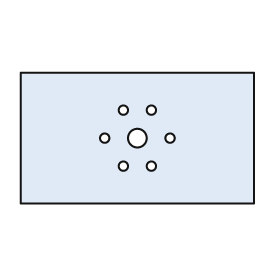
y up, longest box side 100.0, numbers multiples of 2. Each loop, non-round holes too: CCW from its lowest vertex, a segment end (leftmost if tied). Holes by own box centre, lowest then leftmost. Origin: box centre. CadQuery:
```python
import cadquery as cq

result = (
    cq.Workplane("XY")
    .moveTo(-50.0, -28.0)
    .lineTo(50.0, -28.0)
    .lineTo(50.0, 28.0)
    .lineTo(-50.0, 28.0)
    .close()
    .moveTo(-6.0, -12.0)
    .circle(2.0)
    .moveTo(6.0, -12.0)
    .circle(2.0)
    .moveTo(-14.0, 0.0)
    .circle(2.0)
    .moveTo(0.0, 0.0)
    .circle(4.0)
    .moveTo(14.0, 0.0)
    .circle(2.0)
    .moveTo(-6.0, 12.0)
    .circle(2.0)
    .moveTo(6.0, 12.0)
    .circle(2.0)
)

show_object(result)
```